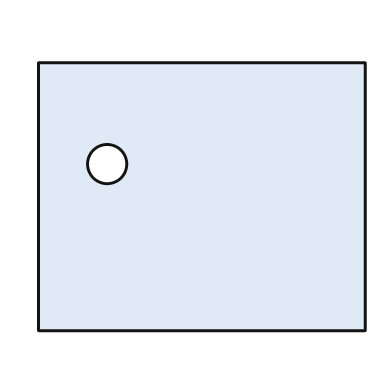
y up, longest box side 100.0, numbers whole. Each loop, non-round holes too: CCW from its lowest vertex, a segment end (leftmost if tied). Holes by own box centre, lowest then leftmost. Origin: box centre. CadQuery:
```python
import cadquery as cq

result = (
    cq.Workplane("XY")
    .moveTo(-50.0, -41.0)
    .lineTo(50.0, -41.0)
    .lineTo(50.0, 41.0)
    .lineTo(-50.0, 41.0)
    .close()
    .moveTo(-29.0, 10.0)
    .circle(6.0)
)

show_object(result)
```